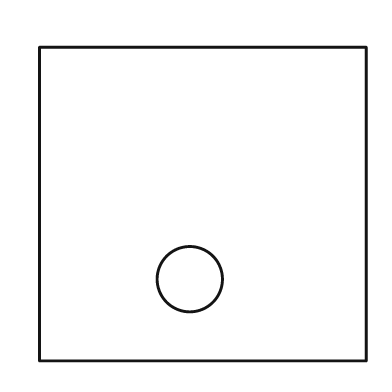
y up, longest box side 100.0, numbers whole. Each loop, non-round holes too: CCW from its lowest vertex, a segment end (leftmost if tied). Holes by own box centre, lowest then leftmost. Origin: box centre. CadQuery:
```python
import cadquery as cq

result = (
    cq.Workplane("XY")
    .moveTo(-50.0, -48.0)
    .lineTo(50.0, -48.0)
    .lineTo(50.0, 48.0)
    .lineTo(-50.0, 48.0)
    .close()
    .moveTo(-4.0, -23.0)
    .circle(10.0)
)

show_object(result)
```